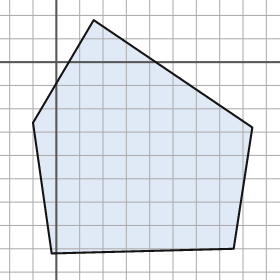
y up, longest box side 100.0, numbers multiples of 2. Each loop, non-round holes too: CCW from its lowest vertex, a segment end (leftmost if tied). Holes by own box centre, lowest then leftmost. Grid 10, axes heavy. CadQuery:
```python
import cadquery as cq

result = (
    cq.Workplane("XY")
    .moveTo(-2.0, -82.0)
    .lineTo(76.0, -80.0)
    .lineTo(84.0, -28.0)
    .lineTo(16.0, 18.0)
    .lineTo(-10.0, -26.0)
    .close()
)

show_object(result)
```